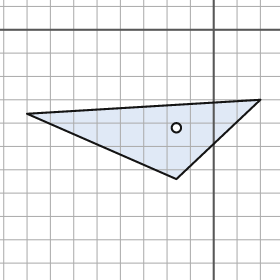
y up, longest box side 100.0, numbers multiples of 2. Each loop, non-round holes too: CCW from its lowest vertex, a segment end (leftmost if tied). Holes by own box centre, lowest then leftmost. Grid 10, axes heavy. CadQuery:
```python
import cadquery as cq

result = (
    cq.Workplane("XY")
    .moveTo(-16.0, -64.0)
    .lineTo(20.0, -30.0)
    .lineTo(-80.0, -36.0)
    .close()
    .moveTo(-16.0, -42.0)
    .circle(2.0)
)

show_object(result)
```